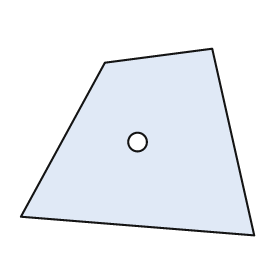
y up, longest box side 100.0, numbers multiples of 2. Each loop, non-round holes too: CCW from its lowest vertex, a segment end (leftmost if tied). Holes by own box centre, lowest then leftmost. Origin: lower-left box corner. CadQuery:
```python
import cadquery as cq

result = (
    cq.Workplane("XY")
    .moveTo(100.0, 0.0)
    .lineTo(82.0, 80.0)
    .lineTo(36.0, 74.0)
    .lineTo(0.0, 8.0)
    .close()
    .moveTo(50.0, 40.0)
    .circle(4.0)
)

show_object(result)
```